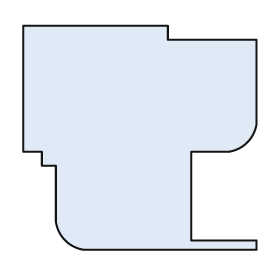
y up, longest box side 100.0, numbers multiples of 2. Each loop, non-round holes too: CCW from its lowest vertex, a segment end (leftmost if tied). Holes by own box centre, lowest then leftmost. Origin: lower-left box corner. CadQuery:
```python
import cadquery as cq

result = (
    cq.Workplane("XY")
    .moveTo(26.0, 0.0)
    .lineTo(100.0, 0.0)
    .lineTo(100.0, 4.0)
    .lineTo(72.0, 4.0)
    .lineTo(72.0, 42.0)
    .lineTo(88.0, 42.0)
    .threePointArc((96.0, 46.0), (100.0, 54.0))
    .lineTo(100.0, 90.0)
    .lineTo(62.0, 90.0)
    .lineTo(62.0, 96.0)
    .lineTo(0.0, 96.0)
    .lineTo(0.0, 42.0)
    .lineTo(8.0, 42.0)
    .lineTo(8.0, 36.0)
    .lineTo(14.0, 36.0)
    .lineTo(14.0, 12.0)
    .threePointArc((18.0, 4.0), (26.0, 0.0))
    .close()
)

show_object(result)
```